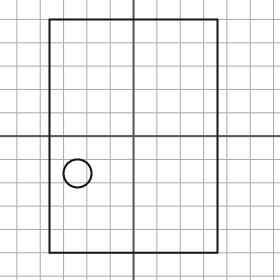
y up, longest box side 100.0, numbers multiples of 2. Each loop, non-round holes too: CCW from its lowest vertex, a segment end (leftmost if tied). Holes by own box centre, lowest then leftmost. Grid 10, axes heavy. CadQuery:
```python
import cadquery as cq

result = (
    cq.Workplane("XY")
    .moveTo(-36.0, -50.0)
    .lineTo(36.0, -50.0)
    .lineTo(36.0, 50.0)
    .lineTo(-36.0, 50.0)
    .close()
    .moveTo(-24.0, -16.0)
    .circle(6.0)
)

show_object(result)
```